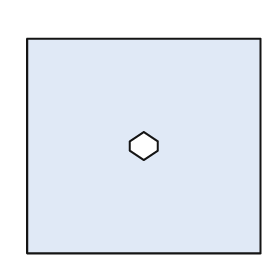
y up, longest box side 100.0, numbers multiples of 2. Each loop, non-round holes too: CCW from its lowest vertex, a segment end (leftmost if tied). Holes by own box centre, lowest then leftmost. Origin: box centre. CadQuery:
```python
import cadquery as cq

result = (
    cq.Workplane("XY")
    .moveTo(-50.0, -46.0)
    .lineTo(50.0, -46.0)
    .lineTo(50.0, 46.0)
    .lineTo(-50.0, 46.0)
    .close()
    .moveTo(0.0, -6.0)
    .lineTo(6.0, -2.0)
    .lineTo(6.0, 2.0)
    .lineTo(0.0, 6.0)
    .lineTo(-6.0, 2.0)
    .lineTo(-6.0, -2.0)
    .close()
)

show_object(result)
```